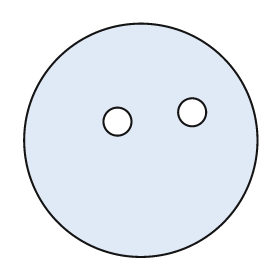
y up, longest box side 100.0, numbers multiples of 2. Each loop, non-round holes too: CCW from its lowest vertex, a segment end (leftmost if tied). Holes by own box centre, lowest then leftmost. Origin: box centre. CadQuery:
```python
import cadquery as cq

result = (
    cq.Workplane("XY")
    .moveTo(0.0, 0.0)
    .circle(50.0)
    .moveTo(-10.0, 8.0)
    .circle(6.0)
    .moveTo(22.0, 12.0)
    .circle(6.0)
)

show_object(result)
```